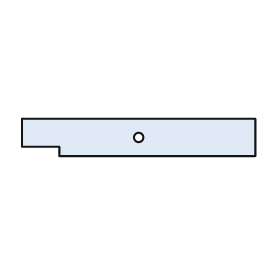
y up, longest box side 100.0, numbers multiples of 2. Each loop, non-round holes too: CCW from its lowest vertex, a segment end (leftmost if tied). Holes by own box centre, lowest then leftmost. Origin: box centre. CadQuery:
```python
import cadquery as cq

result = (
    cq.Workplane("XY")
    .moveTo(-34.0, -8.0)
    .lineTo(50.0, -8.0)
    .lineTo(50.0, 8.0)
    .lineTo(-50.0, 8.0)
    .lineTo(-50.0, -4.0)
    .lineTo(-34.0, -4.0)
    .close()
    .moveTo(0.0, 0.0)
    .circle(2.0)
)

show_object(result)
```